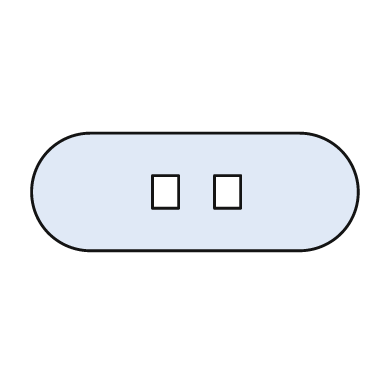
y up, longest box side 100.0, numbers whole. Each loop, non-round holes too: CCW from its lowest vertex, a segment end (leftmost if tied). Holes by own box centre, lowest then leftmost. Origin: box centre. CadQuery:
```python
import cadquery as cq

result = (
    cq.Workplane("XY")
    .moveTo(-32.0, -18.0)
    .lineTo(32.0, -18.0)
    .threePointArc((50.0, 0.0), (32.0, 18.0))
    .lineTo(-32.0, 18.0)
    .threePointArc((-50.0, 0.0), (-32.0, -18.0))
    .close()
    .moveTo(-13.0, -5.0)
    .lineTo(-5.0, -5.0)
    .lineTo(-5.0, 5.0)
    .lineTo(-13.0, 5.0)
    .close()
    .moveTo(6.0, -5.0)
    .lineTo(14.0, -5.0)
    .lineTo(14.0, 5.0)
    .lineTo(6.0, 5.0)
    .close()
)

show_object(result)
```